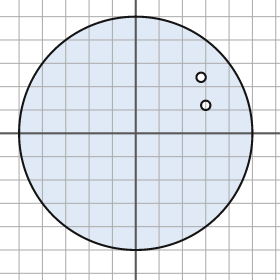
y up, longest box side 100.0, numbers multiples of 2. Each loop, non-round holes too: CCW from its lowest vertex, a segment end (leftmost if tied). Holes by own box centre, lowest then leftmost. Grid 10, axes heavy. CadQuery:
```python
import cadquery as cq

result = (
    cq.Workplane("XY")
    .moveTo(0.0, 0.0)
    .circle(50.0)
    .moveTo(30.0, 12.0)
    .circle(2.0)
    .moveTo(28.0, 24.0)
    .circle(2.0)
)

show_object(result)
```